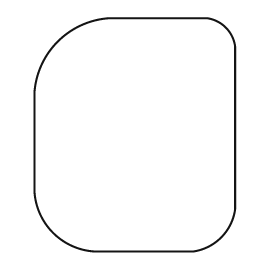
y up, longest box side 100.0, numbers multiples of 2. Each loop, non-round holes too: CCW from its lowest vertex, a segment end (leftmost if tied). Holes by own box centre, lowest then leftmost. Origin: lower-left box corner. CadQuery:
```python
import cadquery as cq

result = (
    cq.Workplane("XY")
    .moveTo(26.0, 0.0)
    .lineTo(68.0, 0.0)
    .threePointArc((80.0, 6.0), (86.0, 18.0))
    .lineTo(86.0, 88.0)
    .threePointArc((82.0, 96.0), (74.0, 100.0))
    .lineTo(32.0, 100.0)
    .threePointArc((10.0, 90.0), (0.0, 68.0))
    .lineTo(0.0, 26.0)
    .threePointArc((8.0, 8.0), (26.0, 0.0))
    .close()
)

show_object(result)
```